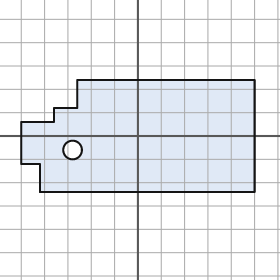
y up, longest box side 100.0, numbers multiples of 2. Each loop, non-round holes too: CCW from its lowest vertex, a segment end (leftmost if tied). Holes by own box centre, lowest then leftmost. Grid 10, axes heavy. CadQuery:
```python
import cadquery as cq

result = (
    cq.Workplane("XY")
    .moveTo(-42.0, -24.0)
    .lineTo(50.0, -24.0)
    .lineTo(50.0, 24.0)
    .lineTo(-26.0, 24.0)
    .lineTo(-26.0, 12.0)
    .lineTo(-36.0, 12.0)
    .lineTo(-36.0, 6.0)
    .lineTo(-50.0, 6.0)
    .lineTo(-50.0, -12.0)
    .lineTo(-42.0, -12.0)
    .close()
    .moveTo(-28.0, -6.0)
    .circle(4.0)
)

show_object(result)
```